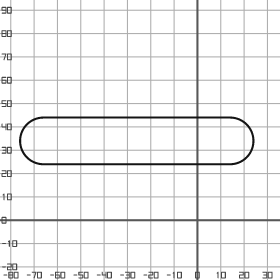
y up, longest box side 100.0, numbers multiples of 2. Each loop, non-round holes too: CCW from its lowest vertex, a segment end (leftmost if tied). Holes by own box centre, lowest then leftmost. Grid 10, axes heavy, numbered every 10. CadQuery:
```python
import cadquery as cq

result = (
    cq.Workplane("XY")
    .moveTo(-66.0, 24.0)
    .lineTo(14.0, 24.0)
    .threePointArc((24.0, 34.0), (14.0, 44.0))
    .lineTo(-66.0, 44.0)
    .threePointArc((-76.0, 34.0), (-66.0, 24.0))
    .close()
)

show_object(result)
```